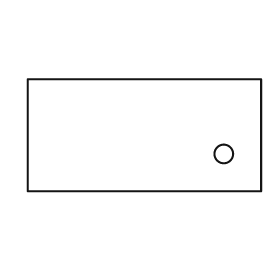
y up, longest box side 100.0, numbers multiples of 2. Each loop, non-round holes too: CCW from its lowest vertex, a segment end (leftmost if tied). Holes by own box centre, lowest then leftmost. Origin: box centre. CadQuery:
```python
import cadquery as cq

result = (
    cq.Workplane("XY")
    .moveTo(-50.0, -24.0)
    .lineTo(50.0, -24.0)
    .lineTo(50.0, 24.0)
    .lineTo(-50.0, 24.0)
    .close()
    .moveTo(34.0, -8.0)
    .circle(4.0)
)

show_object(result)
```